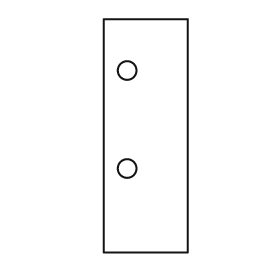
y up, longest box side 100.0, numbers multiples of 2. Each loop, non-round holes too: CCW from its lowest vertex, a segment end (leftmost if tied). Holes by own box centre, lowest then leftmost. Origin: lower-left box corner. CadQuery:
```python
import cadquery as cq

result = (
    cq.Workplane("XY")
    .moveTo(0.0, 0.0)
    .lineTo(36.0, 0.0)
    .lineTo(36.0, 100.0)
    .lineTo(0.0, 100.0)
    .close()
    .moveTo(10.0, 36.0)
    .circle(4.0)
    .moveTo(10.0, 78.0)
    .circle(4.0)
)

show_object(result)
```